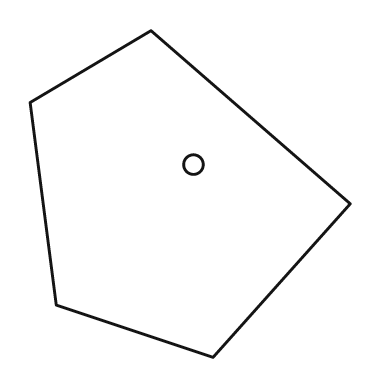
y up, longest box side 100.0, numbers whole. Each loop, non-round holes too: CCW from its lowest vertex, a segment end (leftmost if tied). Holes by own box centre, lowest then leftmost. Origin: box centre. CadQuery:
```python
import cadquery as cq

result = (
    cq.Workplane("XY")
    .moveTo(7.0, -50.0)
    .lineTo(49.0, -3.0)
    .lineTo(-12.0, 50.0)
    .lineTo(-49.0, 28.0)
    .lineTo(-41.0, -34.0)
    .close()
    .moveTo(1.0, 9.0)
    .circle(3.0)
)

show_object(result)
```